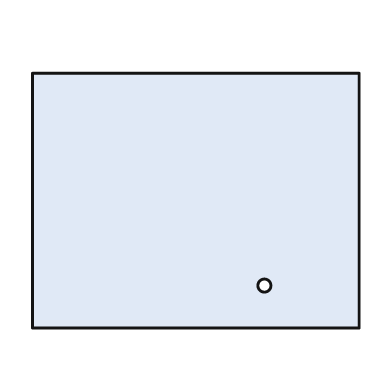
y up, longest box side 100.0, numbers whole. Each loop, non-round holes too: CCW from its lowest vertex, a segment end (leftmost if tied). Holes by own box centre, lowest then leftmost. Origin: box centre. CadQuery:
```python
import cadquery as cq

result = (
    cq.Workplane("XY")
    .moveTo(-50.0, -39.0)
    .lineTo(50.0, -39.0)
    .lineTo(50.0, 39.0)
    .lineTo(-50.0, 39.0)
    .close()
    .moveTo(21.0, -26.0)
    .circle(2.0)
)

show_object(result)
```